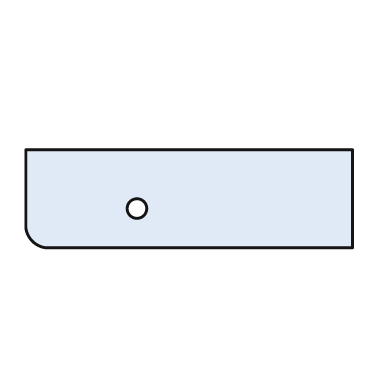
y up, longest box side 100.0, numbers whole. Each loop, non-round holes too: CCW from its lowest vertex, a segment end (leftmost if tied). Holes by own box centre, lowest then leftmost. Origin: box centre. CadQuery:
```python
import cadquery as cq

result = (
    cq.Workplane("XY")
    .moveTo(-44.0, -15.0)
    .lineTo(50.0, -15.0)
    .lineTo(50.0, 15.0)
    .lineTo(-50.0, 15.0)
    .lineTo(-50.0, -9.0)
    .threePointArc((-48.0, -13.0), (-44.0, -15.0))
    .close()
    .moveTo(-16.0, -3.0)
    .circle(3.0)
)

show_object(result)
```